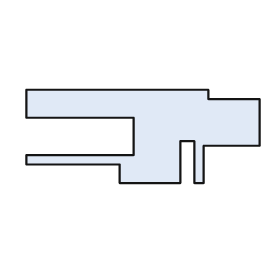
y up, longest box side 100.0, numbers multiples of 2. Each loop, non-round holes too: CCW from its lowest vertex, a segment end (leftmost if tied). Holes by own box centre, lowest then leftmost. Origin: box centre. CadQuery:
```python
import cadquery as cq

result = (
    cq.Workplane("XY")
    .moveTo(-10.0, -20.0)
    .lineTo(16.0, -20.0)
    .lineTo(16.0, -2.0)
    .lineTo(22.0, -2.0)
    .lineTo(22.0, -20.0)
    .lineTo(26.0, -20.0)
    .lineTo(26.0, -4.0)
    .lineTo(50.0, -4.0)
    .lineTo(50.0, 16.0)
    .lineTo(28.0, 16.0)
    .lineTo(28.0, 20.0)
    .lineTo(-50.0, 20.0)
    .lineTo(-50.0, 8.0)
    .lineTo(-4.0, 8.0)
    .lineTo(-4.0, -8.0)
    .lineTo(-50.0, -8.0)
    .lineTo(-50.0, -12.0)
    .lineTo(-10.0, -12.0)
    .close()
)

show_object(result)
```